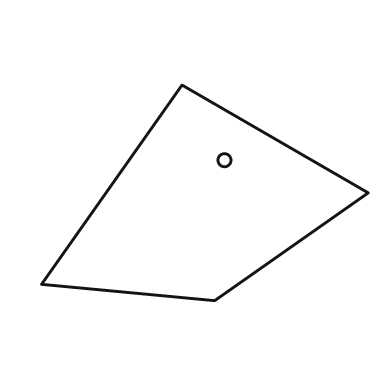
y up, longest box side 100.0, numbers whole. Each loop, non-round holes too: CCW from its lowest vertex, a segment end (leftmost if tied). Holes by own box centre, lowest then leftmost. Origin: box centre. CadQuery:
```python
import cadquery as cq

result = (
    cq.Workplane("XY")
    .moveTo(3.0, -33.0)
    .lineTo(50.0, 0.0)
    .lineTo(-7.0, 33.0)
    .lineTo(-50.0, -28.0)
    .close()
    .moveTo(6.0, 10.0)
    .circle(2.0)
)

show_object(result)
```